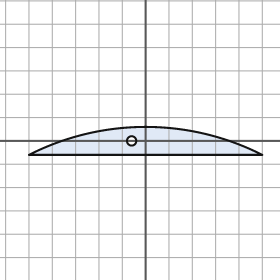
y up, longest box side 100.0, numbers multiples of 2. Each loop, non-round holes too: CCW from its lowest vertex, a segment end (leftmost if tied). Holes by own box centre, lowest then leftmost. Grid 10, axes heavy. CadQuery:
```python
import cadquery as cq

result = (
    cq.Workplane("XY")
    .moveTo(-50.0, -6.0)
    .lineTo(50.0, -6.0)
    .threePointArc((0.0, 6.0), (-50.0, -6.0))
    .close()
    .moveTo(-6.0, 0.0)
    .circle(2.0)
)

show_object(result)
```